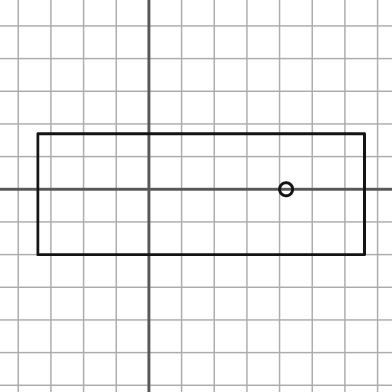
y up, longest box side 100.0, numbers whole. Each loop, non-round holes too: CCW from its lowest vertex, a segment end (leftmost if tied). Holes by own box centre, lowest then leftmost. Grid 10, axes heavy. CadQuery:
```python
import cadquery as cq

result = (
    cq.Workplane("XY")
    .moveTo(-34.0, -20.0)
    .lineTo(66.0, -20.0)
    .lineTo(66.0, 17.0)
    .lineTo(-34.0, 17.0)
    .close()
    .moveTo(42.0, 0.0)
    .circle(2.0)
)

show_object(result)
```